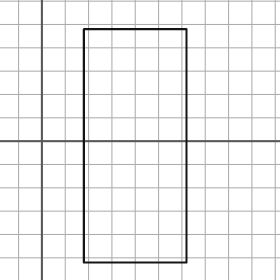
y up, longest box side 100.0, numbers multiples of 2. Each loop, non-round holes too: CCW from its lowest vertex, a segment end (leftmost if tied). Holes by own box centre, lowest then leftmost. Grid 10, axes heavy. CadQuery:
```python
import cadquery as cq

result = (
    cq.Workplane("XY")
    .moveTo(18.0, -52.0)
    .lineTo(62.0, -52.0)
    .lineTo(62.0, 48.0)
    .lineTo(18.0, 48.0)
    .close()
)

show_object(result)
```